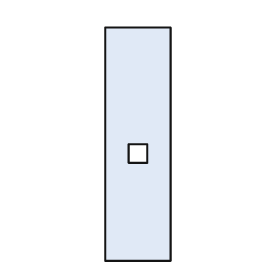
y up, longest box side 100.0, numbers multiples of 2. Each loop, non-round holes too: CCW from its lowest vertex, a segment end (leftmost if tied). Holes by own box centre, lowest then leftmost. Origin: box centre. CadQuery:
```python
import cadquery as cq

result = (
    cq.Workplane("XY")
    .moveTo(-14.0, -50.0)
    .lineTo(14.0, -50.0)
    .lineTo(14.0, 50.0)
    .lineTo(-14.0, 50.0)
    .close()
    .moveTo(-4.0, -8.0)
    .lineTo(4.0, -8.0)
    .lineTo(4.0, 0.0)
    .lineTo(-4.0, 0.0)
    .close()
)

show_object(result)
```